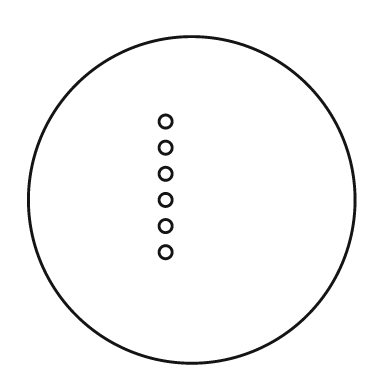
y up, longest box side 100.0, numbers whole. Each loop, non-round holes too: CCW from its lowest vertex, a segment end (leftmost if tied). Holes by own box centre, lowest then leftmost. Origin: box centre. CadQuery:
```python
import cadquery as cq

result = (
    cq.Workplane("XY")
    .moveTo(0.0, 0.0)
    .circle(50.0)
    .moveTo(-8.0, -16.0)
    .circle(2.0)
    .moveTo(-8.0, -8.0)
    .circle(2.0)
    .moveTo(-8.0, 0.0)
    .circle(2.0)
    .moveTo(-8.0, 8.0)
    .circle(2.0)
    .moveTo(-8.0, 16.0)
    .circle(2.0)
    .moveTo(-8.0, 24.0)
    .circle(2.0)
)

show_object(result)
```